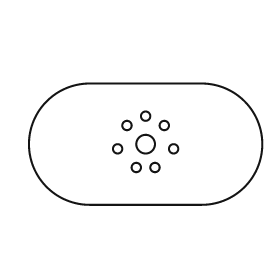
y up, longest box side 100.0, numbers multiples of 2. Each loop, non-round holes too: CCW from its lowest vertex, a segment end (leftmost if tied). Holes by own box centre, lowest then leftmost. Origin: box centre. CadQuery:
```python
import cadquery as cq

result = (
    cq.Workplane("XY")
    .moveTo(-24.0, -26.0)
    .lineTo(24.0, -26.0)
    .threePointArc((50.0, 0.0), (24.0, 26.0))
    .lineTo(-24.0, 26.0)
    .threePointArc((-50.0, 0.0), (-24.0, -26.0))
    .close()
    .moveTo(-4.0, -10.0)
    .circle(2.0)
    .moveTo(4.0, -10.0)
    .circle(2.0)
    .moveTo(-12.0, -2.0)
    .circle(2.0)
    .moveTo(12.0, -2.0)
    .circle(2.0)
    .moveTo(0.0, 0.0)
    .circle(4.0)
    .moveTo(-8.0, 8.0)
    .circle(2.0)
    .moveTo(8.0, 8.0)
    .circle(2.0)
    .moveTo(0.0, 12.0)
    .circle(2.0)
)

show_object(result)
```